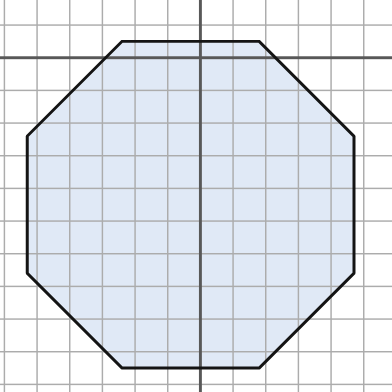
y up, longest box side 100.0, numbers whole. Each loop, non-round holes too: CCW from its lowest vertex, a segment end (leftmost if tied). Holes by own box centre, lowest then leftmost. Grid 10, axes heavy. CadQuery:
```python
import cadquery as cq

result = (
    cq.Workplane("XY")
    .moveTo(-24.0, -95.0)
    .lineTo(18.0, -95.0)
    .lineTo(47.0, -66.0)
    .lineTo(47.0, -24.0)
    .lineTo(18.0, 5.0)
    .lineTo(-24.0, 5.0)
    .lineTo(-53.0, -24.0)
    .lineTo(-53.0, -66.0)
    .close()
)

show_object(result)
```